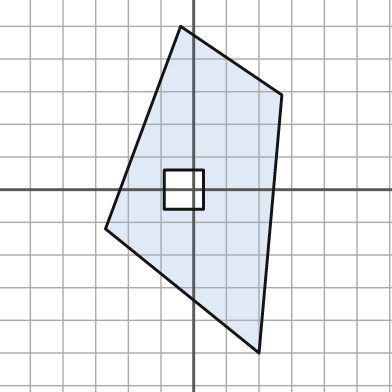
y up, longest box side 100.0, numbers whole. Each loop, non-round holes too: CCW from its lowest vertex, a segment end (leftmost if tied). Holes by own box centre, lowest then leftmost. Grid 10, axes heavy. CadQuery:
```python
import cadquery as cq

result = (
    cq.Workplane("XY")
    .moveTo(20.0, -50.0)
    .lineTo(27.0, 29.0)
    .lineTo(-4.0, 50.0)
    .lineTo(-27.0, -12.0)
    .close()
    .moveTo(-9.0, -6.0)
    .lineTo(3.0, -6.0)
    .lineTo(3.0, 6.0)
    .lineTo(-9.0, 6.0)
    .close()
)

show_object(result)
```